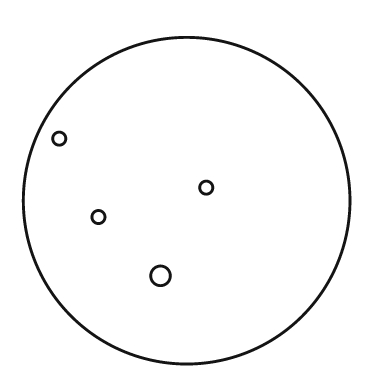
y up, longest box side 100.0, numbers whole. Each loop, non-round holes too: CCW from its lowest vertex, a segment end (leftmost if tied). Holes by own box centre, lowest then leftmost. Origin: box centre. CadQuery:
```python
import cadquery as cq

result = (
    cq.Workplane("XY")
    .moveTo(0.0, 0.0)
    .circle(50.0)
    .moveTo(-8.0, -23.0)
    .circle(3.0)
    .moveTo(-27.0, -5.0)
    .circle(2.0)
    .moveTo(6.0, 4.0)
    .circle(2.0)
    .moveTo(-39.0, 19.0)
    .circle(2.0)
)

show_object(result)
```